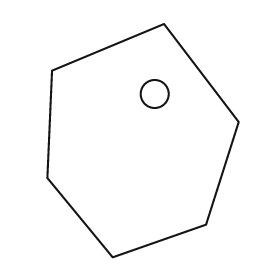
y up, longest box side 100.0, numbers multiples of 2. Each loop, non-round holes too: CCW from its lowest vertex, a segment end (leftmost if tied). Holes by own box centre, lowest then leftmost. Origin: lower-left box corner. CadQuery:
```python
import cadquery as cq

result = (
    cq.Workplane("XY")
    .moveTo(28.0, 0.0)
    .lineTo(68.0, 14.0)
    .lineTo(82.0, 58.0)
    .lineTo(50.0, 100.0)
    .lineTo(2.0, 80.0)
    .lineTo(0.0, 34.0)
    .close()
    .moveTo(46.0, 70.0)
    .circle(6.0)
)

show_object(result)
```